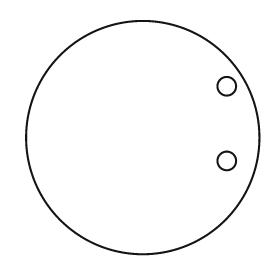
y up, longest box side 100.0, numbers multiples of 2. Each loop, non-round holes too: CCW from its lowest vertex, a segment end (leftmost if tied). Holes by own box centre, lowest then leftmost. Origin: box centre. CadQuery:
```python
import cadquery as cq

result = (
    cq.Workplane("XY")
    .moveTo(0.0, 0.0)
    .circle(50.0)
    .moveTo(36.0, -10.0)
    .circle(4.0)
    .moveTo(36.0, 22.0)
    .circle(4.0)
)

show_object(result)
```